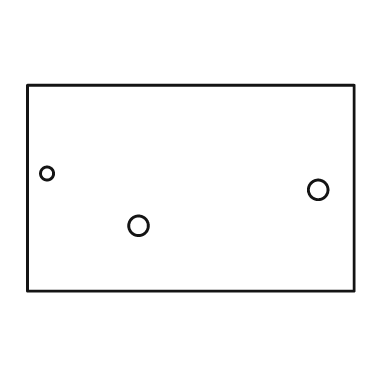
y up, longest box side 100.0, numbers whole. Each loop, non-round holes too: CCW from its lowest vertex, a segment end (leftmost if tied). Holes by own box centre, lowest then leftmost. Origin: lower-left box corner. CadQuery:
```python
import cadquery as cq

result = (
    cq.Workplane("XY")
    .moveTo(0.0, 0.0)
    .lineTo(100.0, 0.0)
    .lineTo(100.0, 63.0)
    .lineTo(0.0, 63.0)
    .close()
    .moveTo(34.0, 20.0)
    .circle(3.0)
    .moveTo(89.0, 31.0)
    .circle(3.0)
    .moveTo(6.0, 36.0)
    .circle(2.0)
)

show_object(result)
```